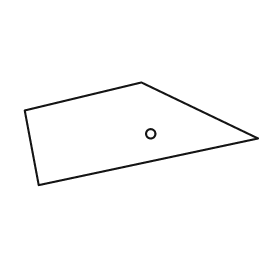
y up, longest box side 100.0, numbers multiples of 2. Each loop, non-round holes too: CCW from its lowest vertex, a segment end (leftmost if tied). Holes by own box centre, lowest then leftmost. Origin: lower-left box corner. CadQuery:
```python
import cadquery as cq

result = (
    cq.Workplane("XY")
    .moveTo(6.0, 0.0)
    .lineTo(100.0, 20.0)
    .lineTo(50.0, 44.0)
    .lineTo(0.0, 32.0)
    .close()
    .moveTo(54.0, 22.0)
    .circle(2.0)
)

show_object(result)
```